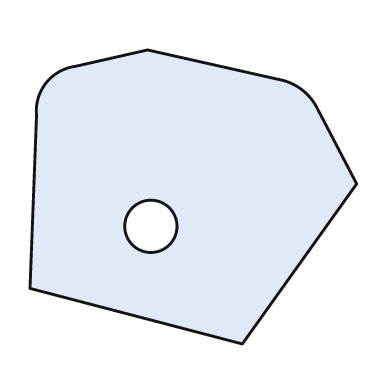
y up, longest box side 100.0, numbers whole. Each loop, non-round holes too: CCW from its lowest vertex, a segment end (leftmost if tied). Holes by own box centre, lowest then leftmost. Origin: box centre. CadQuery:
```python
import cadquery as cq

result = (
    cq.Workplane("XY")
    .moveTo(15.0, -45.0)
    .lineTo(50.0, 4.0)
    .lineTo(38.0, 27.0)
    .threePointArc((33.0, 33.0), (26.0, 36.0))
    .lineTo(-14.0, 45.0)
    .lineTo(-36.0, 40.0)
    .threePointArc((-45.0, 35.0), (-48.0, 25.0))
    .lineTo(-50.0, -28.0)
    .close()
    .moveTo(-13.0, -9.0)
    .circle(8.0)
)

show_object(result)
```